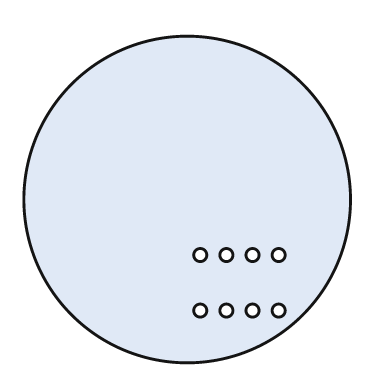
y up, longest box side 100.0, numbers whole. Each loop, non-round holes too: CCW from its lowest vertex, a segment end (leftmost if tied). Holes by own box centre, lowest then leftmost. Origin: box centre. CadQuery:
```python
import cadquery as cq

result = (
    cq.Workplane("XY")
    .moveTo(0.0, 0.0)
    .circle(50.0)
    .moveTo(4.0, -34.0)
    .circle(2.0)
    .moveTo(12.0, -34.0)
    .circle(2.0)
    .moveTo(20.0, -34.0)
    .circle(2.0)
    .moveTo(28.0, -34.0)
    .circle(2.0)
    .moveTo(4.0, -17.0)
    .circle(2.0)
    .moveTo(12.0, -17.0)
    .circle(2.0)
    .moveTo(20.0, -17.0)
    .circle(2.0)
    .moveTo(28.0, -17.0)
    .circle(2.0)
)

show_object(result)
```